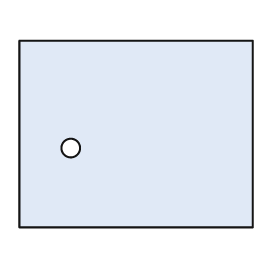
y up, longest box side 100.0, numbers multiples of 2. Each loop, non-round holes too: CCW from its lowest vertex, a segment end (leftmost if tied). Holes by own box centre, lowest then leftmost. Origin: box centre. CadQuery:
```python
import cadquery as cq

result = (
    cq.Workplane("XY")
    .moveTo(-50.0, -40.0)
    .lineTo(50.0, -40.0)
    .lineTo(50.0, 40.0)
    .lineTo(-50.0, 40.0)
    .close()
    .moveTo(-28.0, -6.0)
    .circle(4.0)
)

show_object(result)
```